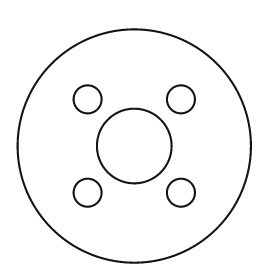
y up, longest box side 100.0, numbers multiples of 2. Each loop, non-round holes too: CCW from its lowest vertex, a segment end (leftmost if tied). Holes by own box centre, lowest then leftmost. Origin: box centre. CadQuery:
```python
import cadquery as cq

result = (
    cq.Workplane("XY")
    .moveTo(0.0, 0.0)
    .circle(50.0)
    .moveTo(-20.0, -20.0)
    .circle(6.0)
    .moveTo(20.0, -20.0)
    .circle(6.0)
    .moveTo(0.0, 0.0)
    .circle(16.0)
    .moveTo(-20.0, 20.0)
    .circle(6.0)
    .moveTo(20.0, 20.0)
    .circle(6.0)
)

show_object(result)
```